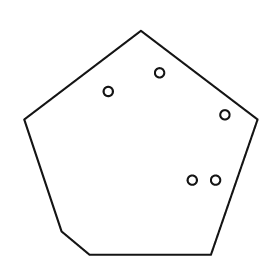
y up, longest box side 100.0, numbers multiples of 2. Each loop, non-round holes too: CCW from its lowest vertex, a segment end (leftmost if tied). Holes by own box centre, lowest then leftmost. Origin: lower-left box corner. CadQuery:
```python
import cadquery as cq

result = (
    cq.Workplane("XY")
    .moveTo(28.0, 0.0)
    .lineTo(80.0, 0.0)
    .lineTo(100.0, 58.0)
    .lineTo(50.0, 96.0)
    .lineTo(0.0, 58.0)
    .lineTo(16.0, 10.0)
    .close()
    .moveTo(72.0, 32.0)
    .circle(2.0)
    .moveTo(82.0, 32.0)
    .circle(2.0)
    .moveTo(86.0, 60.0)
    .circle(2.0)
    .moveTo(36.0, 70.0)
    .circle(2.0)
    .moveTo(58.0, 78.0)
    .circle(2.0)
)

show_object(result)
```